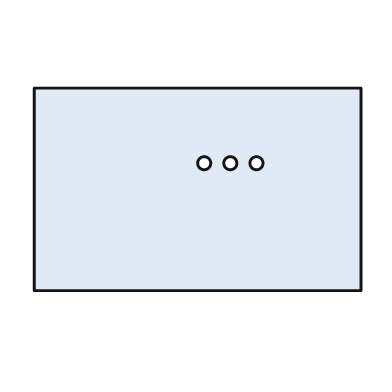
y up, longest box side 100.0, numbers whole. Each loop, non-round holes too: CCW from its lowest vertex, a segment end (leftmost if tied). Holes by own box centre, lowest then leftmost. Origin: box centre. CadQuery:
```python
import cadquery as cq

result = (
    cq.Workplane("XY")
    .moveTo(-50.0, -31.0)
    .lineTo(50.0, -31.0)
    .lineTo(50.0, 31.0)
    .lineTo(-50.0, 31.0)
    .close()
    .moveTo(2.0, 8.0)
    .circle(2.0)
    .moveTo(10.0, 8.0)
    .circle(2.0)
    .moveTo(18.0, 8.0)
    .circle(2.0)
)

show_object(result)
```